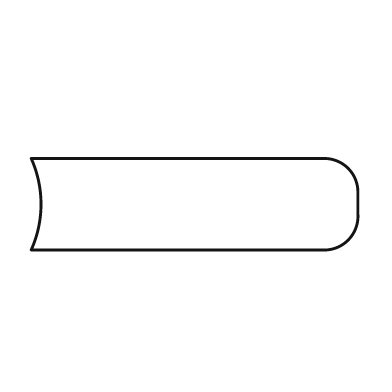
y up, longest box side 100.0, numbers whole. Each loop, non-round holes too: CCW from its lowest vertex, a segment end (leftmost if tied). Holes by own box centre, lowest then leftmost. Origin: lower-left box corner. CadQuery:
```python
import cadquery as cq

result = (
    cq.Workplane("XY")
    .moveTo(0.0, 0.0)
    .lineTo(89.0, 0.0)
    .threePointArc((97.0, 3.0), (100.0, 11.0))
    .lineTo(100.0, 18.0)
    .threePointArc((97.0, 25.0), (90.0, 28.0))
    .lineTo(0.0, 28.0)
    .threePointArc((3.0, 14.0), (0.0, 0.0))
    .close()
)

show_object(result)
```